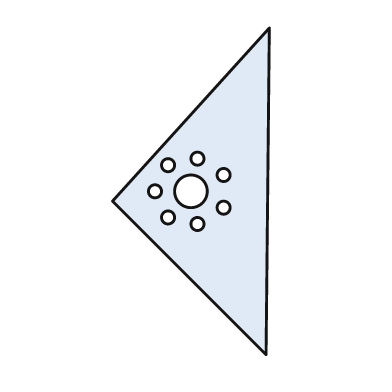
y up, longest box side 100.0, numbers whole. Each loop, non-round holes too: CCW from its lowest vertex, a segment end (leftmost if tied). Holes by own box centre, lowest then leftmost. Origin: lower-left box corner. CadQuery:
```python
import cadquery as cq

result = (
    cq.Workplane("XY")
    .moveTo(47.0, 0.0)
    .lineTo(48.0, 100.0)
    .lineTo(0.0, 47.0)
    .close()
    .moveTo(26.0, 40.0)
    .circle(2.0)
    .moveTo(17.0, 42.0)
    .circle(2.0)
    .moveTo(34.0, 45.0)
    .circle(2.0)
    .moveTo(13.0, 50.0)
    .circle(2.0)
    .moveTo(24.0, 50.0)
    .circle(5.0)
    .moveTo(34.0, 55.0)
    .circle(2.0)
    .moveTo(17.0, 58.0)
    .circle(2.0)
    .moveTo(26.0, 60.0)
    .circle(2.0)
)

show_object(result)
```